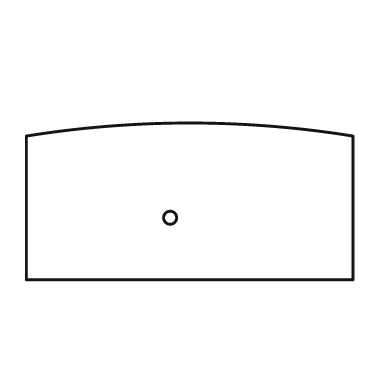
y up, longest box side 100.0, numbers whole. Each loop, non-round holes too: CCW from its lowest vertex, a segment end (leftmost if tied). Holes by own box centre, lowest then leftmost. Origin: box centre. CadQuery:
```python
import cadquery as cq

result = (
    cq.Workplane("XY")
    .moveTo(-50.0, -24.0)
    .lineTo(50.0, -24.0)
    .lineTo(50.0, 20.0)
    .threePointArc((0.0, 24.0), (-50.0, 20.0))
    .close()
    .moveTo(-6.0, -5.0)
    .circle(2.0)
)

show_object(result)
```